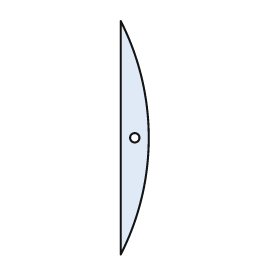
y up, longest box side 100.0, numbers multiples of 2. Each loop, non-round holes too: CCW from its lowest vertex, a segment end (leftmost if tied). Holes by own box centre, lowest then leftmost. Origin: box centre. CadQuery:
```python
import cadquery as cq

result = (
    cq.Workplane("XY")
    .moveTo(-6.0, -50.0)
    .threePointArc((6.0, 0.0), (-6.0, 50.0))
    .close()
    .moveTo(0.0, 0.0)
    .circle(2.0)
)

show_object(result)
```